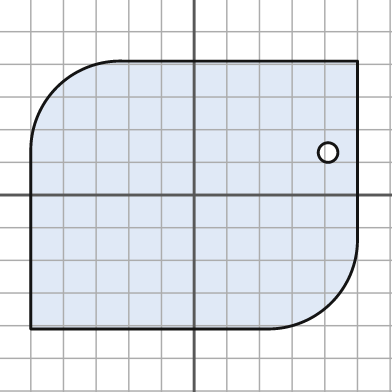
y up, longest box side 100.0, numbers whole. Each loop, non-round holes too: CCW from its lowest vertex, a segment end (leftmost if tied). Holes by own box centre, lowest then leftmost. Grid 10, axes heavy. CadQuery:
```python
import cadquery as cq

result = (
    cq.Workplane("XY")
    .moveTo(-50.0, -41.0)
    .lineTo(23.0, -41.0)
    .threePointArc((42.0, -33.0), (50.0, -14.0))
    .lineTo(50.0, 41.0)
    .lineTo(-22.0, 41.0)
    .threePointArc((-42.0, 33.0), (-50.0, 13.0))
    .close()
    .moveTo(41.0, 13.0)
    .circle(3.0)
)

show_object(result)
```